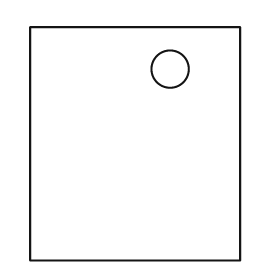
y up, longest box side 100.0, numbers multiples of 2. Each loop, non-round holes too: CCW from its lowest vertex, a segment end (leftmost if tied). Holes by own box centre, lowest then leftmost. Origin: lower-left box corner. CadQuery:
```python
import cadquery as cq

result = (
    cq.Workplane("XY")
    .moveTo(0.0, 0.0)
    .lineTo(90.0, 0.0)
    .lineTo(90.0, 100.0)
    .lineTo(0.0, 100.0)
    .close()
    .moveTo(60.0, 82.0)
    .circle(8.0)
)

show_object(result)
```